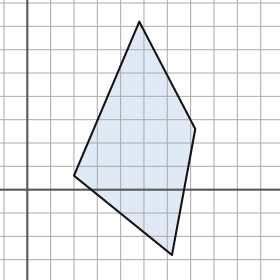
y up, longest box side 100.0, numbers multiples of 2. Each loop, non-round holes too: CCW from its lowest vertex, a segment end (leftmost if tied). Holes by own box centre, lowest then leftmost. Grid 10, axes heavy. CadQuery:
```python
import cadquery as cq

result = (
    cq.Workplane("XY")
    .moveTo(62.0, -28.0)
    .lineTo(72.0, 26.0)
    .lineTo(48.0, 72.0)
    .lineTo(20.0, 6.0)
    .close()
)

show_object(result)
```